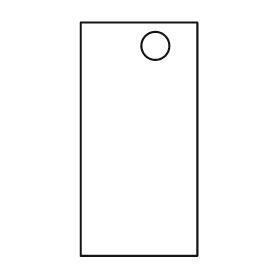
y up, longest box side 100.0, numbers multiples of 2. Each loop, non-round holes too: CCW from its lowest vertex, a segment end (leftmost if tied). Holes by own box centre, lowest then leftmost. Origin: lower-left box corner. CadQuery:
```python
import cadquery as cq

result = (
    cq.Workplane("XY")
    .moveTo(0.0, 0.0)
    .lineTo(50.0, 0.0)
    .lineTo(50.0, 100.0)
    .lineTo(0.0, 100.0)
    .close()
    .moveTo(32.0, 90.0)
    .circle(6.0)
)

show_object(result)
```